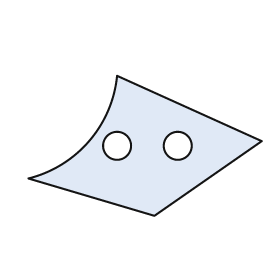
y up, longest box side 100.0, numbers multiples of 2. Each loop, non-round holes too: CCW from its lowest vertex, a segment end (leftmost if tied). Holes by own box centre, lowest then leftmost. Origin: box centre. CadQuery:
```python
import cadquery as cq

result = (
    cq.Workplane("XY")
    .moveTo(4.0, -30.0)
    .lineTo(50.0, 2.0)
    .lineTo(-12.0, 30.0)
    .threePointArc((-24.0, 2.0), (-50.0, -14.0))
    .close()
    .moveTo(-12.0, 0.0)
    .circle(6.0)
    .moveTo(14.0, 0.0)
    .circle(6.0)
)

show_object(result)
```